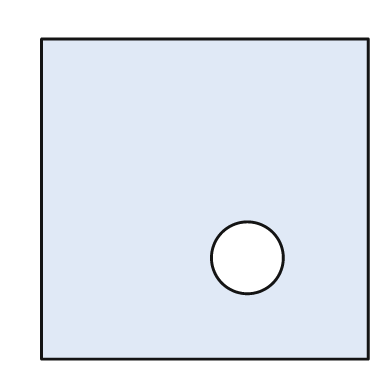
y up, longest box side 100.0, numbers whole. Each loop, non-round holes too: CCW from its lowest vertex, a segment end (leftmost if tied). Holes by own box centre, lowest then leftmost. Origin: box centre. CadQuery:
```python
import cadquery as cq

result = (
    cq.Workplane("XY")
    .moveTo(-50.0, -49.0)
    .lineTo(50.0, -49.0)
    .lineTo(50.0, 49.0)
    .lineTo(-50.0, 49.0)
    .close()
    .moveTo(13.0, -18.0)
    .circle(11.0)
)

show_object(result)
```